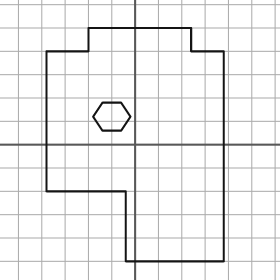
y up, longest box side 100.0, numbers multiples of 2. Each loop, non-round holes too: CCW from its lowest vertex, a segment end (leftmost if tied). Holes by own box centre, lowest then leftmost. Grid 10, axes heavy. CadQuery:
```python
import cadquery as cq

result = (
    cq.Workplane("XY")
    .moveTo(-4.0, -50.0)
    .lineTo(38.0, -50.0)
    .lineTo(38.0, 40.0)
    .lineTo(24.0, 40.0)
    .lineTo(24.0, 50.0)
    .lineTo(-20.0, 50.0)
    .lineTo(-20.0, 40.0)
    .lineTo(-38.0, 40.0)
    .lineTo(-38.0, -20.0)
    .lineTo(-4.0, -20.0)
    .close()
    .moveTo(-14.0, 6.0)
    .lineTo(-6.0, 6.0)
    .lineTo(-2.0, 12.0)
    .lineTo(-6.0, 18.0)
    .lineTo(-14.0, 18.0)
    .lineTo(-18.0, 12.0)
    .close()
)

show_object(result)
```